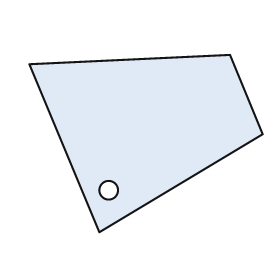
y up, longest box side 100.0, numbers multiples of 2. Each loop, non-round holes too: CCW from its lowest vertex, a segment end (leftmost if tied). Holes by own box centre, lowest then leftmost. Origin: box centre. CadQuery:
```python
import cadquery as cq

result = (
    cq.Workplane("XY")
    .moveTo(-20.0, -38.0)
    .lineTo(50.0, 4.0)
    .lineTo(36.0, 38.0)
    .lineTo(-50.0, 34.0)
    .close()
    .moveTo(-16.0, -20.0)
    .circle(4.0)
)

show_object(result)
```